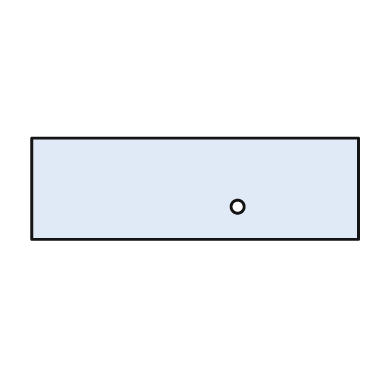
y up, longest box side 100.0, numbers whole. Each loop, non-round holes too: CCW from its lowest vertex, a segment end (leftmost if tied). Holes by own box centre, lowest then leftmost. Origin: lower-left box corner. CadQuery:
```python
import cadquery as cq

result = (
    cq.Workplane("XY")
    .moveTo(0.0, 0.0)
    .lineTo(100.0, 0.0)
    .lineTo(100.0, 31.0)
    .lineTo(0.0, 31.0)
    .close()
    .moveTo(63.0, 10.0)
    .circle(2.0)
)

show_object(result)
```